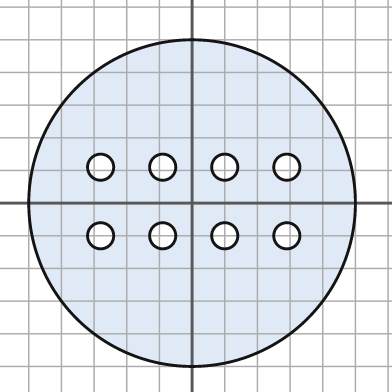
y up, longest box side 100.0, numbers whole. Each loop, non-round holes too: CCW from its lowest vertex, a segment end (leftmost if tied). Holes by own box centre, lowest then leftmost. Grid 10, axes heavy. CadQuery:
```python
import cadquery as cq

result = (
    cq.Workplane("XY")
    .moveTo(0.0, 0.0)
    .circle(50.0)
    .moveTo(-28.0, -10.0)
    .circle(4.0)
    .moveTo(-9.0, -10.0)
    .circle(4.0)
    .moveTo(10.0, -10.0)
    .circle(4.0)
    .moveTo(29.0, -10.0)
    .circle(4.0)
    .moveTo(-28.0, 11.0)
    .circle(4.0)
    .moveTo(-9.0, 11.0)
    .circle(4.0)
    .moveTo(10.0, 11.0)
    .circle(4.0)
    .moveTo(29.0, 11.0)
    .circle(4.0)
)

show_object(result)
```